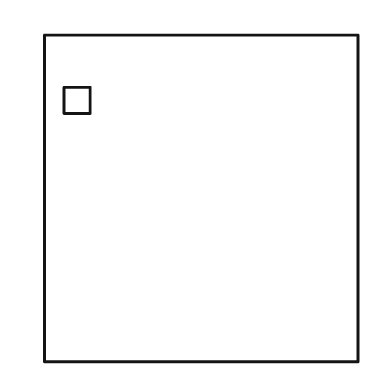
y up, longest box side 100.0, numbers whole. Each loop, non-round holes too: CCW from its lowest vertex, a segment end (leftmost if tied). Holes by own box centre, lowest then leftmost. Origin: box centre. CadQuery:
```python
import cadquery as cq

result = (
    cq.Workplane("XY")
    .moveTo(-48.0, -50.0)
    .lineTo(48.0, -50.0)
    .lineTo(48.0, 50.0)
    .lineTo(-48.0, 50.0)
    .close()
    .moveTo(-42.0, 26.0)
    .lineTo(-34.0, 26.0)
    .lineTo(-34.0, 34.0)
    .lineTo(-42.0, 34.0)
    .close()
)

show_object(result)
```